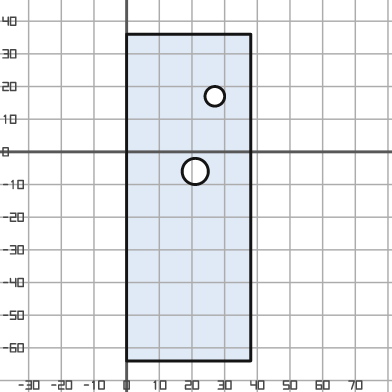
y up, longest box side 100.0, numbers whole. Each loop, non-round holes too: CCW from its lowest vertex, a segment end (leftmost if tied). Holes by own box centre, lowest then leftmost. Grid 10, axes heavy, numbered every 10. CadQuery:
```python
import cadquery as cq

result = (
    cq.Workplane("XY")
    .moveTo(0.0, -64.0)
    .lineTo(38.0, -64.0)
    .lineTo(38.0, 36.0)
    .lineTo(0.0, 36.0)
    .close()
    .moveTo(21.0, -6.0)
    .circle(4.0)
    .moveTo(27.0, 17.0)
    .circle(3.0)
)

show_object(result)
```